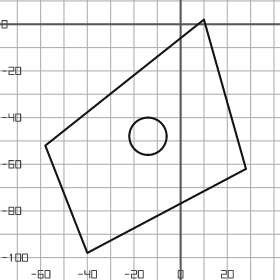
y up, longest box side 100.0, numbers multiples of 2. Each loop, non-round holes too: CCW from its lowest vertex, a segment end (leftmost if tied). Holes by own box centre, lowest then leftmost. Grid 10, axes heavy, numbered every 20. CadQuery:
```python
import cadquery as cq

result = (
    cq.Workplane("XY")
    .moveTo(-40.0, -98.0)
    .lineTo(28.0, -62.0)
    .lineTo(10.0, 2.0)
    .lineTo(-58.0, -52.0)
    .close()
    .moveTo(-14.0, -48.0)
    .circle(8.0)
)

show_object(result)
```